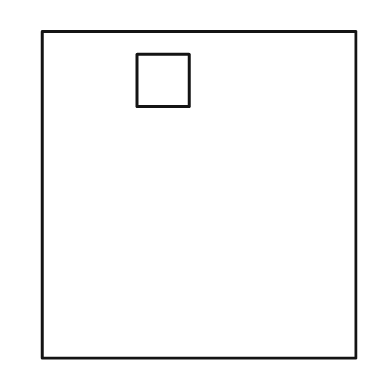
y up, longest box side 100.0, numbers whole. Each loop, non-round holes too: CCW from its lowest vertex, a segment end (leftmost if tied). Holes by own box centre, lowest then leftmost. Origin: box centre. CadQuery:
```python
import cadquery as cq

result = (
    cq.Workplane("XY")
    .moveTo(-48.0, -50.0)
    .lineTo(48.0, -50.0)
    .lineTo(48.0, 50.0)
    .lineTo(-48.0, 50.0)
    .close()
    .moveTo(-19.0, 27.0)
    .lineTo(-3.0, 27.0)
    .lineTo(-3.0, 43.0)
    .lineTo(-19.0, 43.0)
    .close()
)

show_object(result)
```